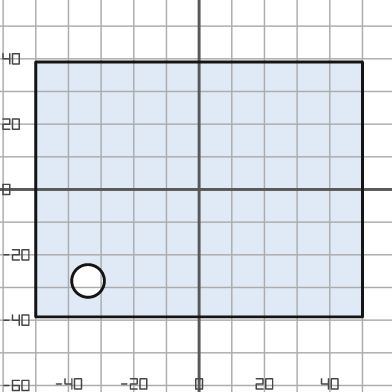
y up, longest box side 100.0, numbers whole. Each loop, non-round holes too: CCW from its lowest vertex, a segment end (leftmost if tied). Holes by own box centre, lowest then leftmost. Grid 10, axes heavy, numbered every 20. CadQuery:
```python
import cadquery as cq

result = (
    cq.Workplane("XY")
    .moveTo(-50.0, -39.0)
    .lineTo(50.0, -39.0)
    .lineTo(50.0, 39.0)
    .lineTo(-50.0, 39.0)
    .close()
    .moveTo(-34.0, -28.0)
    .circle(5.0)
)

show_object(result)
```